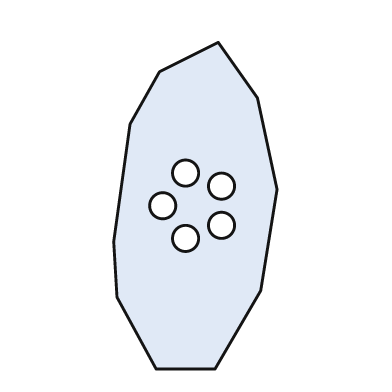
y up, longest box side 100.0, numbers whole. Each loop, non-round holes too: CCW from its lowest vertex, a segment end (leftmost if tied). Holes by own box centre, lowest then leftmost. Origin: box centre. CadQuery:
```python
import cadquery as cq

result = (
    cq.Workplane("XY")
    .moveTo(-12.0, -50.0)
    .lineTo(6.0, -50.0)
    .lineTo(20.0, -26.0)
    .lineTo(25.0, 5.0)
    .lineTo(19.0, 33.0)
    .lineTo(7.0, 50.0)
    .lineTo(-11.0, 41.0)
    .lineTo(-20.0, 25.0)
    .lineTo(-25.0, -11.0)
    .lineTo(-24.0, -28.0)
    .close()
    .moveTo(-3.0, -10.0)
    .circle(4.0)
    .moveTo(8.0, -6.0)
    .circle(4.0)
    .moveTo(-10.0, 0.0)
    .circle(4.0)
    .moveTo(8.0, 6.0)
    .circle(4.0)
    .moveTo(-3.0, 10.0)
    .circle(4.0)
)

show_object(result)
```